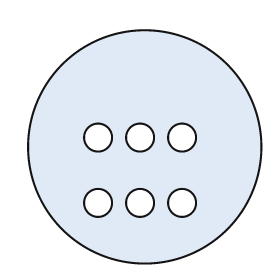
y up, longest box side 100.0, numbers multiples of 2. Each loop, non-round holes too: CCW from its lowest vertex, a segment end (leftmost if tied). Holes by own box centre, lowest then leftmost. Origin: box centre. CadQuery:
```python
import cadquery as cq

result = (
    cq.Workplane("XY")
    .moveTo(0.0, 0.0)
    .circle(50.0)
    .moveTo(-20.0, -24.0)
    .circle(6.0)
    .moveTo(-2.0, -24.0)
    .circle(6.0)
    .moveTo(16.0, -24.0)
    .circle(6.0)
    .moveTo(-20.0, 4.0)
    .circle(6.0)
    .moveTo(-2.0, 4.0)
    .circle(6.0)
    .moveTo(16.0, 4.0)
    .circle(6.0)
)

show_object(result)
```